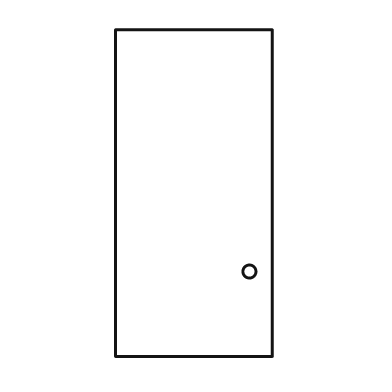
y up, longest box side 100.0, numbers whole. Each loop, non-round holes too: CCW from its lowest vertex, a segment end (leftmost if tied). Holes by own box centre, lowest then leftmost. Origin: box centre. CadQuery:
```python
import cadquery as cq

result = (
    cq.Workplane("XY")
    .moveTo(-24.0, -50.0)
    .lineTo(24.0, -50.0)
    .lineTo(24.0, 50.0)
    .lineTo(-24.0, 50.0)
    .close()
    .moveTo(17.0, -24.0)
    .circle(2.0)
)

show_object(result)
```